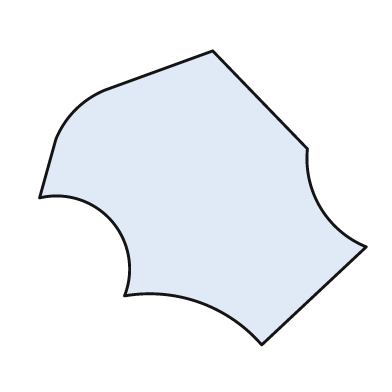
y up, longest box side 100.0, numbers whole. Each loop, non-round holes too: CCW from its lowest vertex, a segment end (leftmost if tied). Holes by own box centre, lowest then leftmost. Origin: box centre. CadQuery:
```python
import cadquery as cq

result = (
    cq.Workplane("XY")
    .moveTo(18.0, -45.0)
    .lineTo(50.0, -15.0)
    .threePointArc((36.0, -3.0), (32.0, 15.0))
    .lineTo(3.0, 45.0)
    .lineTo(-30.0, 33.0)
    .threePointArc((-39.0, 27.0), (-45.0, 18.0))
    .lineTo(-50.0, 0.0)
    .threePointArc((-28.0, -7.0), (-24.0, -30.0))
    .threePointArc((-1.0, -32.0), (18.0, -45.0))
    .close()
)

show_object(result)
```